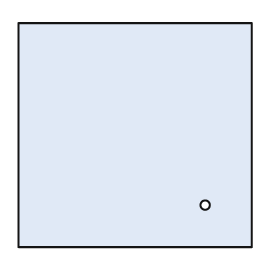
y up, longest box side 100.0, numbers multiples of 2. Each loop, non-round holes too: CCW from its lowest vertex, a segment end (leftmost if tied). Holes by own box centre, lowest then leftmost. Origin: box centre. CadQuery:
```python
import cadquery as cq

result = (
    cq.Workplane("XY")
    .moveTo(-50.0, -48.0)
    .lineTo(50.0, -48.0)
    .lineTo(50.0, 48.0)
    .lineTo(-50.0, 48.0)
    .close()
    .moveTo(30.0, -30.0)
    .circle(2.0)
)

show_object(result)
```